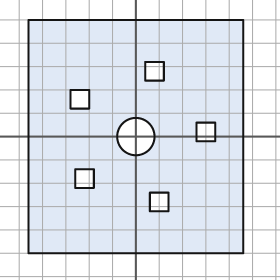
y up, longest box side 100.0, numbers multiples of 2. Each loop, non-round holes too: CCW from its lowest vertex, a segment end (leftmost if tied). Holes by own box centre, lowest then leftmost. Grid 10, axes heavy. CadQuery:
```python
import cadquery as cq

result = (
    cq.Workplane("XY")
    .moveTo(-46.0, -50.0)
    .lineTo(46.0, -50.0)
    .lineTo(46.0, 50.0)
    .lineTo(-46.0, 50.0)
    .close()
    .moveTo(6.0, -32.0)
    .lineTo(14.0, -32.0)
    .lineTo(14.0, -24.0)
    .lineTo(6.0, -24.0)
    .close()
    .moveTo(-26.0, -22.0)
    .lineTo(-18.0, -22.0)
    .lineTo(-18.0, -14.0)
    .lineTo(-26.0, -14.0)
    .close()
    .moveTo(0.0, 0.0)
    .circle(8.0)
    .moveTo(26.0, -2.0)
    .lineTo(34.0, -2.0)
    .lineTo(34.0, 6.0)
    .lineTo(26.0, 6.0)
    .close()
    .moveTo(-28.0, 12.0)
    .lineTo(-20.0, 12.0)
    .lineTo(-20.0, 20.0)
    .lineTo(-28.0, 20.0)
    .close()
    .moveTo(4.0, 24.0)
    .lineTo(12.0, 24.0)
    .lineTo(12.0, 32.0)
    .lineTo(4.0, 32.0)
    .close()
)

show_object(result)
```